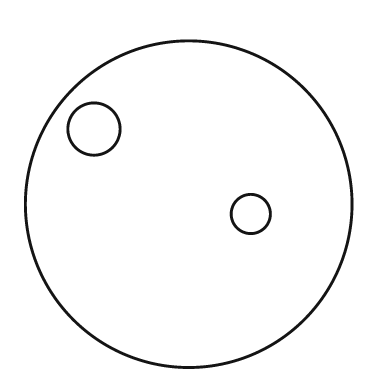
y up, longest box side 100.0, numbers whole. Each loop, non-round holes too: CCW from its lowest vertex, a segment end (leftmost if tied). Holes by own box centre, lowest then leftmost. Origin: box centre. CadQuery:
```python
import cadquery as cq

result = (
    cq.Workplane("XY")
    .moveTo(0.0, 0.0)
    .circle(50.0)
    .moveTo(19.0, -3.0)
    .circle(6.0)
    .moveTo(-29.0, 23.0)
    .circle(8.0)
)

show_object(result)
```